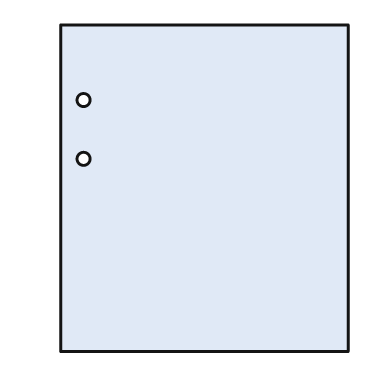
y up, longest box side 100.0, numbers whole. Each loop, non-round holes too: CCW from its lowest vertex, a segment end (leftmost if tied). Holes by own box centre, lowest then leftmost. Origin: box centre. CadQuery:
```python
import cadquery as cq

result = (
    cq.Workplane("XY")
    .moveTo(-44.0, -50.0)
    .lineTo(44.0, -50.0)
    .lineTo(44.0, 50.0)
    .lineTo(-44.0, 50.0)
    .close()
    .moveTo(-37.0, 9.0)
    .circle(2.0)
    .moveTo(-37.0, 27.0)
    .circle(2.0)
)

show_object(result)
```